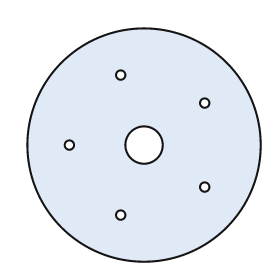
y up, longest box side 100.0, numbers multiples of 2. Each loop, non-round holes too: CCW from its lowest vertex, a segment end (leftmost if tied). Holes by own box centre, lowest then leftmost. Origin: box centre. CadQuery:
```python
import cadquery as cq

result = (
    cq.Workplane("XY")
    .moveTo(0.0, 0.0)
    .circle(50.0)
    .moveTo(-10.0, -30.0)
    .circle(2.0)
    .moveTo(26.0, -18.0)
    .circle(2.0)
    .moveTo(-32.0, 0.0)
    .circle(2.0)
    .moveTo(0.0, 0.0)
    .circle(8.0)
    .moveTo(26.0, 18.0)
    .circle(2.0)
    .moveTo(-10.0, 30.0)
    .circle(2.0)
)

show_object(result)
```